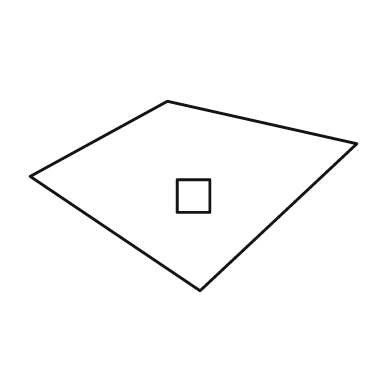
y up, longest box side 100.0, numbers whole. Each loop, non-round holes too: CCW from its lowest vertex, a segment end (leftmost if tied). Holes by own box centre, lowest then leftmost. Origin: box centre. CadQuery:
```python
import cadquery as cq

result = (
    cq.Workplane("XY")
    .moveTo(2.0, -29.0)
    .lineTo(50.0, 16.0)
    .lineTo(-8.0, 29.0)
    .lineTo(-50.0, 6.0)
    .close()
    .moveTo(-5.0, -5.0)
    .lineTo(5.0, -5.0)
    .lineTo(5.0, 5.0)
    .lineTo(-5.0, 5.0)
    .close()
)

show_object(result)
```